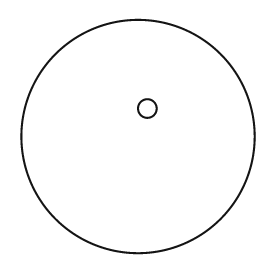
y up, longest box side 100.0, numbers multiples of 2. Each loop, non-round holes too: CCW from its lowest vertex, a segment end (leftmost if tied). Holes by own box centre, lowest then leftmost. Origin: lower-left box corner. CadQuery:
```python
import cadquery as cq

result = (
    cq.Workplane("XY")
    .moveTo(50.0, 50.0)
    .circle(50.0)
    .moveTo(54.0, 62.0)
    .circle(4.0)
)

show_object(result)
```